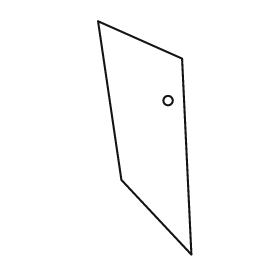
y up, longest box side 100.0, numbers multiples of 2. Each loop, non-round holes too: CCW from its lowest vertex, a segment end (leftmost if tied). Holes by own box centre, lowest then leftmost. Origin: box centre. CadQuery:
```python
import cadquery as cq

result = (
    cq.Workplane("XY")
    .moveTo(20.0, -50.0)
    .lineTo(16.0, 34.0)
    .lineTo(-20.0, 50.0)
    .lineTo(-10.0, -18.0)
    .close()
    .moveTo(10.0, 16.0)
    .circle(2.0)
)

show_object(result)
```